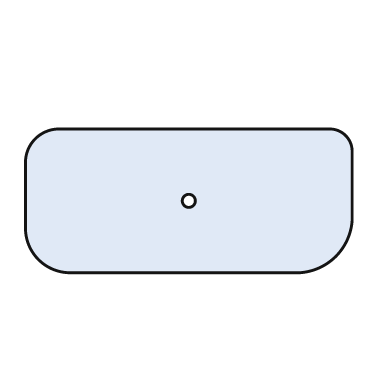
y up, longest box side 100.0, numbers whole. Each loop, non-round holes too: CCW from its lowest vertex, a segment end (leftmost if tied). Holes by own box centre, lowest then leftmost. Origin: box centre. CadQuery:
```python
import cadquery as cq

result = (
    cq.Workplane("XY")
    .moveTo(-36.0, -22.0)
    .lineTo(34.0, -22.0)
    .threePointArc((45.0, -17.0), (50.0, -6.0))
    .lineTo(50.0, 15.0)
    .threePointArc((48.0, 20.0), (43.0, 22.0))
    .lineTo(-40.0, 22.0)
    .threePointArc((-47.0, 19.0), (-50.0, 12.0))
    .lineTo(-50.0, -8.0)
    .threePointArc((-46.0, -18.0), (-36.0, -22.0))
    .close()
    .moveTo(0.0, 0.0)
    .circle(2.0)
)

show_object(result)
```